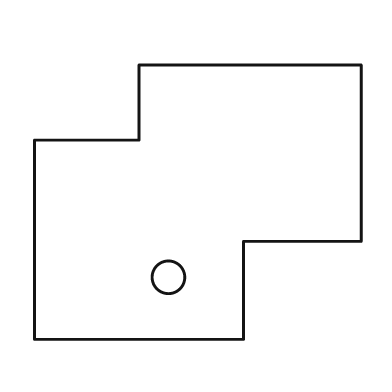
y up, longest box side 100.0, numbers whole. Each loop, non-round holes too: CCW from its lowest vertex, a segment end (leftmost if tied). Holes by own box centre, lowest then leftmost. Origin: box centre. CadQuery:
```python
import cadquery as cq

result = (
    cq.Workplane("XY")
    .moveTo(-50.0, -42.0)
    .lineTo(14.0, -42.0)
    .lineTo(14.0, -12.0)
    .lineTo(50.0, -12.0)
    .lineTo(50.0, 42.0)
    .lineTo(-18.0, 42.0)
    .lineTo(-18.0, 19.0)
    .lineTo(-50.0, 19.0)
    .close()
    .moveTo(-9.0, -23.0)
    .circle(5.0)
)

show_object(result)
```